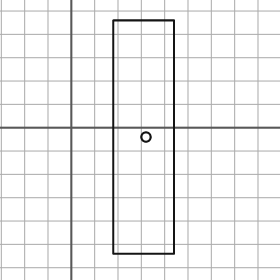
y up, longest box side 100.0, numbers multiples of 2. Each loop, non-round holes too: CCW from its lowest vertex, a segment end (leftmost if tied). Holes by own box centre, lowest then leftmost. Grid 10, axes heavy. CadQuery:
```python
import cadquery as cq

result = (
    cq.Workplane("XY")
    .moveTo(18.0, -54.0)
    .lineTo(44.0, -54.0)
    .lineTo(44.0, 46.0)
    .lineTo(18.0, 46.0)
    .close()
    .moveTo(32.0, -4.0)
    .circle(2.0)
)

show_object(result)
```